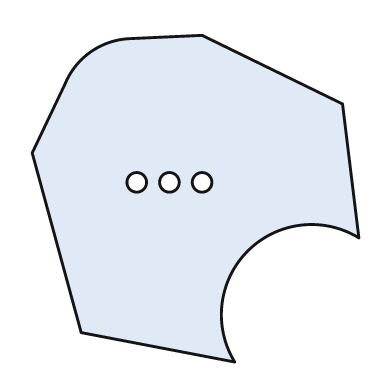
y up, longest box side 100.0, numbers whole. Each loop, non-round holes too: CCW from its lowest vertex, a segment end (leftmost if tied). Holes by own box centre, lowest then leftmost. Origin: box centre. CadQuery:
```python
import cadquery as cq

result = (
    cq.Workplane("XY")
    .moveTo(12.0, -50.0)
    .threePointArc((16.0, -16.0), (50.0, -12.0))
    .lineTo(45.0, 29.0)
    .lineTo(2.0, 50.0)
    .lineTo(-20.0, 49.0)
    .threePointArc((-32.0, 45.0), (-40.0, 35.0))
    .lineTo(-50.0, 14.0)
    .lineTo(-35.0, -41.0)
    .close()
    .moveTo(-18.0, 5.0)
    .circle(3.0)
    .moveTo(-8.0, 5.0)
    .circle(3.0)
    .moveTo(2.0, 5.0)
    .circle(3.0)
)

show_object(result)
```